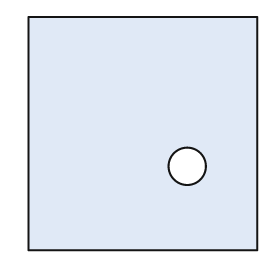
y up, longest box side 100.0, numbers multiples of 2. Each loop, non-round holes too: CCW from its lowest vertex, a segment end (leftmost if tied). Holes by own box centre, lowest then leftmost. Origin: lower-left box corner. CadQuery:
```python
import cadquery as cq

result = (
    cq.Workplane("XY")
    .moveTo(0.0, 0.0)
    .lineTo(98.0, 0.0)
    .lineTo(98.0, 100.0)
    .lineTo(0.0, 100.0)
    .close()
    .moveTo(68.0, 36.0)
    .circle(8.0)
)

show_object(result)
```